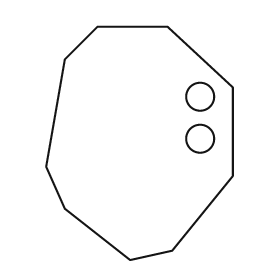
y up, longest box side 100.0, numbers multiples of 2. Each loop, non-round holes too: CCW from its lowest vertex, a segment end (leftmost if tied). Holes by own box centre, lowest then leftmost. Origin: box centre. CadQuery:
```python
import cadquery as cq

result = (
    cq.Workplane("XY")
    .moveTo(-4.0, -50.0)
    .lineTo(14.0, -46.0)
    .lineTo(40.0, -14.0)
    .lineTo(40.0, 24.0)
    .lineTo(12.0, 50.0)
    .lineTo(-18.0, 50.0)
    .lineTo(-32.0, 36.0)
    .lineTo(-40.0, -10.0)
    .lineTo(-32.0, -28.0)
    .close()
    .moveTo(26.0, 2.0)
    .circle(6.0)
    .moveTo(26.0, 20.0)
    .circle(6.0)
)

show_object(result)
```